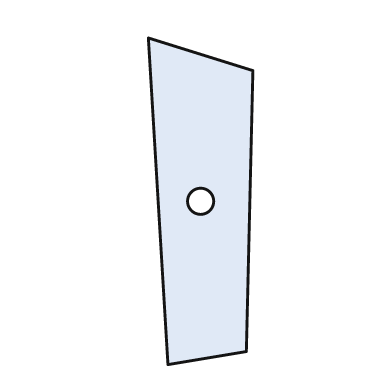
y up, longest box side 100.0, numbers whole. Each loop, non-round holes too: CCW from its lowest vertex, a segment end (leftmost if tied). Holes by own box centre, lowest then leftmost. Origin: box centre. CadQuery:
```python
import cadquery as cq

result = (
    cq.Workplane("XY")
    .moveTo(-10.0, -50.0)
    .lineTo(14.0, -46.0)
    .lineTo(16.0, 40.0)
    .lineTo(-16.0, 50.0)
    .close()
    .moveTo(0.0, 0.0)
    .circle(4.0)
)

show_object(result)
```